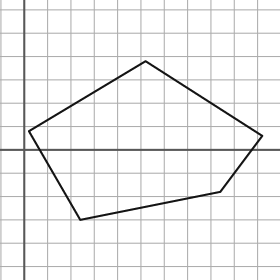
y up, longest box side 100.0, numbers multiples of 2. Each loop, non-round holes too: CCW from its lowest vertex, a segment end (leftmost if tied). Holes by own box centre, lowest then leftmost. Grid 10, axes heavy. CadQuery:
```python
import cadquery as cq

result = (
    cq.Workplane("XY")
    .moveTo(24.0, -30.0)
    .lineTo(84.0, -18.0)
    .lineTo(102.0, 6.0)
    .lineTo(52.0, 38.0)
    .lineTo(2.0, 8.0)
    .close()
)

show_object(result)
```